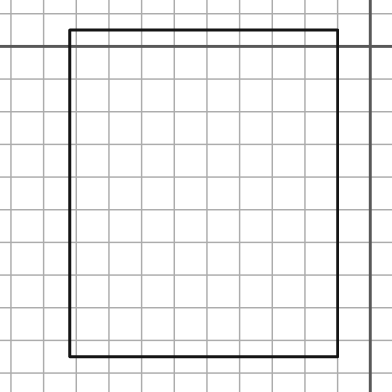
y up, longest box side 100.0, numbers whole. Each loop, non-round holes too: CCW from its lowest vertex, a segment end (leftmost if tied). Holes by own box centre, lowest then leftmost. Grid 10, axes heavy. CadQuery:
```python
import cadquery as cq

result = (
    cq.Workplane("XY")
    .moveTo(-92.0, -95.0)
    .lineTo(-10.0, -95.0)
    .lineTo(-10.0, 5.0)
    .lineTo(-92.0, 5.0)
    .close()
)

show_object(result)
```